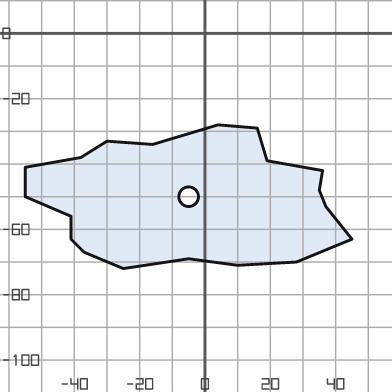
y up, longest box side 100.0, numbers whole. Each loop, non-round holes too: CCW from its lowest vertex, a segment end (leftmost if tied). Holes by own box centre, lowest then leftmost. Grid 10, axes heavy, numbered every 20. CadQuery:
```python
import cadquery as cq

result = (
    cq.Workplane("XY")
    .moveTo(-25.0, -72.0)
    .lineTo(-5.0, -69.0)
    .lineTo(10.0, -71.0)
    .lineTo(28.0, -70.0)
    .lineTo(45.0, -63.0)
    .lineTo(37.0, -53.0)
    .lineTo(35.0, -48.0)
    .lineTo(36.0, -42.0)
    .lineTo(19.0, -39.0)
    .lineTo(16.0, -29.0)
    .lineTo(4.0, -28.0)
    .lineTo(-16.0, -34.0)
    .lineTo(-30.0, -33.0)
    .lineTo(-38.0, -38.0)
    .lineTo(-55.0, -41.0)
    .lineTo(-55.0, -50.0)
    .lineTo(-41.0, -56.0)
    .lineTo(-41.0, -63.0)
    .lineTo(-37.0, -67.0)
    .close()
    .moveTo(-5.0, -50.0)
    .circle(3.0)
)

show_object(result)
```